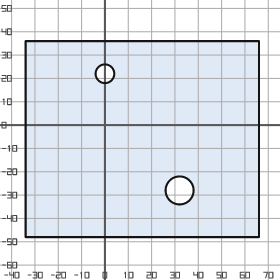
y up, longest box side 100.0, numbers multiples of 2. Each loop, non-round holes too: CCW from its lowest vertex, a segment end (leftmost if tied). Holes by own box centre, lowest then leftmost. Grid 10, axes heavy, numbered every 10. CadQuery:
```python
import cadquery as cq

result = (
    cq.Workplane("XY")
    .moveTo(-34.0, -48.0)
    .lineTo(66.0, -48.0)
    .lineTo(66.0, 36.0)
    .lineTo(-34.0, 36.0)
    .close()
    .moveTo(32.0, -28.0)
    .circle(6.0)
    .moveTo(0.0, 22.0)
    .circle(4.0)
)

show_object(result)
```